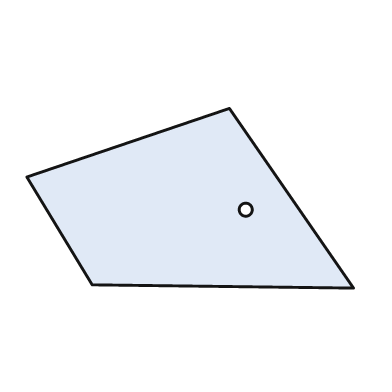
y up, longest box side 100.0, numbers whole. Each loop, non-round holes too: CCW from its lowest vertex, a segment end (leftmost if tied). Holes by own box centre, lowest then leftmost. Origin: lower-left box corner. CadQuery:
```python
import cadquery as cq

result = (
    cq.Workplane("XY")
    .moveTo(100.0, 0.0)
    .lineTo(62.0, 55.0)
    .lineTo(0.0, 34.0)
    .lineTo(20.0, 1.0)
    .close()
    .moveTo(67.0, 24.0)
    .circle(2.0)
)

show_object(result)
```